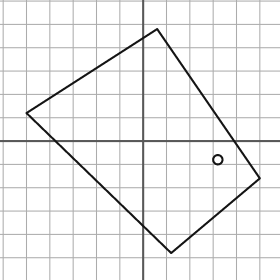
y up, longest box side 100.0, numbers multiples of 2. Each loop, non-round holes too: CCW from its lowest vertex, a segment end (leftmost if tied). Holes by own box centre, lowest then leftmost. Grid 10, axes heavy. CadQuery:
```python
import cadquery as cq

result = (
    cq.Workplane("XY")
    .moveTo(12.0, -48.0)
    .lineTo(50.0, -16.0)
    .lineTo(6.0, 48.0)
    .lineTo(-50.0, 12.0)
    .close()
    .moveTo(32.0, -8.0)
    .circle(2.0)
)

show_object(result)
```